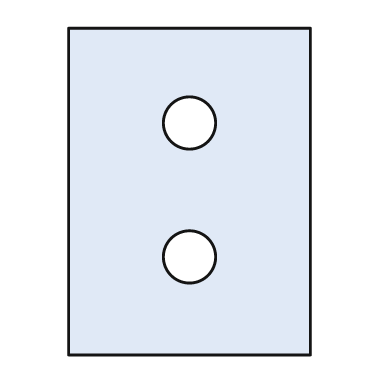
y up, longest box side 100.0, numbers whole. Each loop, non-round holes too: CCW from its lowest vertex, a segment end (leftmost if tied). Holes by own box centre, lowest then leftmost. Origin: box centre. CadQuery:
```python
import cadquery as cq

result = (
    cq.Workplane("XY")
    .moveTo(-37.0, -50.0)
    .lineTo(37.0, -50.0)
    .lineTo(37.0, 50.0)
    .lineTo(-37.0, 50.0)
    .close()
    .moveTo(0.0, -20.0)
    .circle(8.0)
    .moveTo(0.0, 21.0)
    .circle(8.0)
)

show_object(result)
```